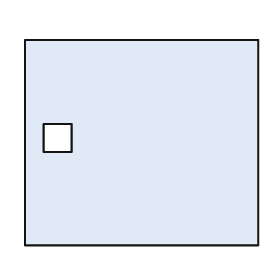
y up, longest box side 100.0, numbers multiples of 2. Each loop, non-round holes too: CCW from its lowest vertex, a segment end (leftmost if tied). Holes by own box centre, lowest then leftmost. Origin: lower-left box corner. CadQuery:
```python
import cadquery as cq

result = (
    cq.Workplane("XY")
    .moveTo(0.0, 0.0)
    .lineTo(100.0, 0.0)
    .lineTo(100.0, 88.0)
    .lineTo(0.0, 88.0)
    .close()
    .moveTo(8.0, 40.0)
    .lineTo(20.0, 40.0)
    .lineTo(20.0, 52.0)
    .lineTo(8.0, 52.0)
    .close()
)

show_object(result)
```